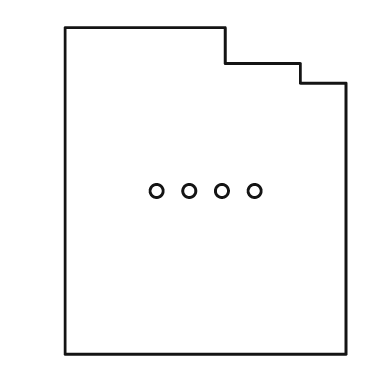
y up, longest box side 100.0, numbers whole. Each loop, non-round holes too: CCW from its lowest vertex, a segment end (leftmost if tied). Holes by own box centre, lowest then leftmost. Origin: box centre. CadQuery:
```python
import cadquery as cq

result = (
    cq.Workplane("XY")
    .moveTo(-43.0, -50.0)
    .lineTo(43.0, -50.0)
    .lineTo(43.0, 33.0)
    .lineTo(29.0, 33.0)
    .lineTo(29.0, 39.0)
    .lineTo(6.0, 39.0)
    .lineTo(6.0, 50.0)
    .lineTo(-43.0, 50.0)
    .close()
    .moveTo(-15.0, 0.0)
    .circle(2.0)
    .moveTo(-5.0, 0.0)
    .circle(2.0)
    .moveTo(5.0, 0.0)
    .circle(2.0)
    .moveTo(15.0, 0.0)
    .circle(2.0)
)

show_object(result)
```